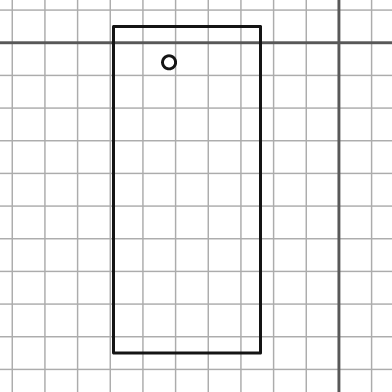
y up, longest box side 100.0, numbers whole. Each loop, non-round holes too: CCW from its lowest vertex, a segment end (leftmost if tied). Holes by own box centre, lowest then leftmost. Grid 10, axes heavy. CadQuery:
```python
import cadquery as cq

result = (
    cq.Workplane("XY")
    .moveTo(-69.0, -95.0)
    .lineTo(-24.0, -95.0)
    .lineTo(-24.0, 5.0)
    .lineTo(-69.0, 5.0)
    .close()
    .moveTo(-52.0, -6.0)
    .circle(2.0)
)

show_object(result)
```